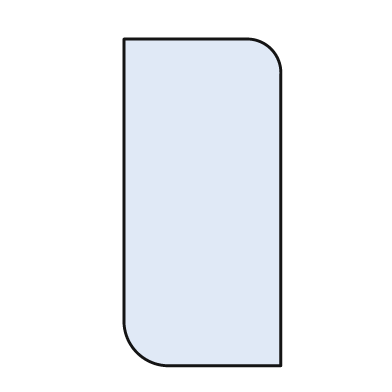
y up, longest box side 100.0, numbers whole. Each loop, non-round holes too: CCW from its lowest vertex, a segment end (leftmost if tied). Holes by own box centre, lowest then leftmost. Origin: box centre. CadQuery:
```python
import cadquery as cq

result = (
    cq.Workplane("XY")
    .moveTo(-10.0, -50.0)
    .lineTo(24.0, -50.0)
    .lineTo(24.0, 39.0)
    .threePointArc((21.0, 47.0), (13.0, 50.0))
    .lineTo(-24.0, 50.0)
    .lineTo(-24.0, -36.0)
    .threePointArc((-20.0, -46.0), (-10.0, -50.0))
    .close()
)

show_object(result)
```